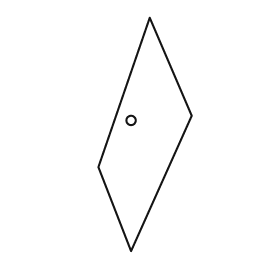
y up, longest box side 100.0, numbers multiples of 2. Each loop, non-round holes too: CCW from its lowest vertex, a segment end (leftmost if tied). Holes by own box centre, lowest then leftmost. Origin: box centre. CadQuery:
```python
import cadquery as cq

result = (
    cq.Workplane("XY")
    .moveTo(-6.0, -50.0)
    .lineTo(20.0, 8.0)
    .lineTo(2.0, 50.0)
    .lineTo(-20.0, -14.0)
    .close()
    .moveTo(-6.0, 6.0)
    .circle(2.0)
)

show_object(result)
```